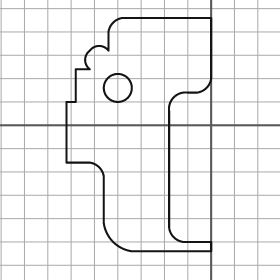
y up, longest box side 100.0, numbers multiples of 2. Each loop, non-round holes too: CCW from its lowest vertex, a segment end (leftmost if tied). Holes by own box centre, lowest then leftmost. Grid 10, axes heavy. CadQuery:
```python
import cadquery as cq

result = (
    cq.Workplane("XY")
    .moveTo(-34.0, -54.0)
    .lineTo(0.0, -54.0)
    .lineTo(0.0, -50.0)
    .lineTo(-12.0, -50.0)
    .threePointArc((-16.0, -48.0), (-18.0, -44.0))
    .lineTo(-18.0, 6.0)
    .threePointArc((-16.0, 12.0), (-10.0, 14.0))
    .lineTo(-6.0, 14.0)
    .threePointArc((-2.0, 16.0), (0.0, 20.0))
    .lineTo(0.0, 46.0)
    .lineTo(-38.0, 46.0)
    .threePointArc((-42.0, 44.0), (-44.0, 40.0))
    .lineTo(-44.0, 32.0)
    .threePointArc((-48.0, 34.0), (-52.0, 32.0))
    .threePointArc((-54.0, 28.0), (-52.0, 24.0))
    .lineTo(-58.0, 24.0)
    .lineTo(-58.0, 10.0)
    .lineTo(-62.0, 10.0)
    .lineTo(-62.0, -16.0)
    .lineTo(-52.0, -16.0)
    .threePointArc((-48.0, -18.0), (-46.0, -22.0))
    .lineTo(-46.0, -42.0)
    .threePointArc((-42.0, -50.0), (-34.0, -54.0))
    .close()
    .moveTo(-40.0, 16.0)
    .circle(6.0)
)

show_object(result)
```